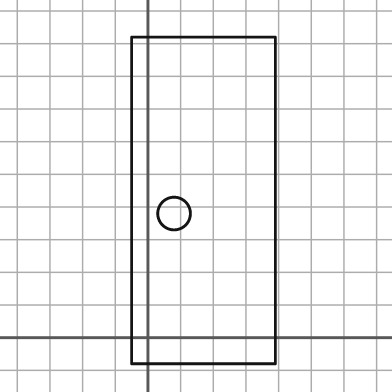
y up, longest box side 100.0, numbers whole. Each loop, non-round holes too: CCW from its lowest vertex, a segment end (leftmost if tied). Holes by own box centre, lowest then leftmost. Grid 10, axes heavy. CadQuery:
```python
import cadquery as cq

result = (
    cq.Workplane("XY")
    .moveTo(-5.0, -8.0)
    .lineTo(39.0, -8.0)
    .lineTo(39.0, 92.0)
    .lineTo(-5.0, 92.0)
    .close()
    .moveTo(8.0, 38.0)
    .circle(5.0)
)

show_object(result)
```